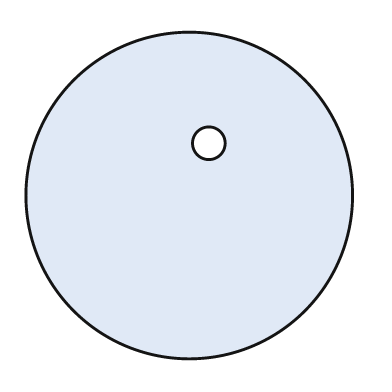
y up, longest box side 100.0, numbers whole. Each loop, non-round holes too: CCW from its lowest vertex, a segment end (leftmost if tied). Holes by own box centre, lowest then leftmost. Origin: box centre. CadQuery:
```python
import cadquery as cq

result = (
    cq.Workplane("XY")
    .moveTo(0.0, 0.0)
    .circle(50.0)
    .moveTo(6.0, 16.0)
    .circle(5.0)
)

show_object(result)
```